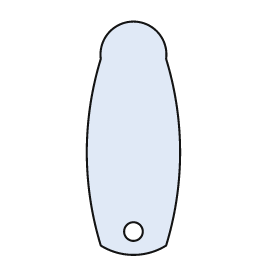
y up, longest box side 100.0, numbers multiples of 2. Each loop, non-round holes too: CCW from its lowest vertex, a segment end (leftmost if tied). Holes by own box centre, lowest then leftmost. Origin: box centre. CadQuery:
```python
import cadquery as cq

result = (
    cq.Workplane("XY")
    .moveTo(-14.0, -46.0)
    .threePointArc((0.0, -50.0), (14.0, -46.0))
    .threePointArc((20.0, -6.0), (14.0, 34.0))
    .threePointArc((0.0, 50.0), (-14.0, 34.0))
    .threePointArc((-20.0, -6.0), (-14.0, -46.0))
    .close()
    .moveTo(0.0, -40.0)
    .circle(4.0)
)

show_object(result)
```